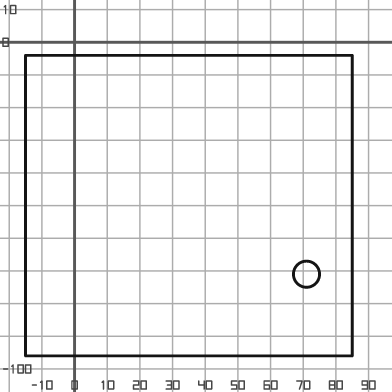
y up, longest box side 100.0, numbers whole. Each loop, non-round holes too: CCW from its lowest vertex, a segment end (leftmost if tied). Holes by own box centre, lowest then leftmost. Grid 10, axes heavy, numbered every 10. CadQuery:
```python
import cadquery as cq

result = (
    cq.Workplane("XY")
    .moveTo(-15.0, -96.0)
    .lineTo(85.0, -96.0)
    .lineTo(85.0, -4.0)
    .lineTo(-15.0, -4.0)
    .close()
    .moveTo(71.0, -71.0)
    .circle(4.0)
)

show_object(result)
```